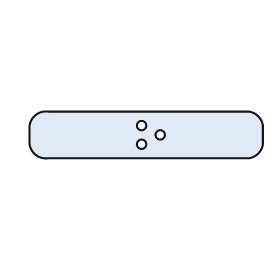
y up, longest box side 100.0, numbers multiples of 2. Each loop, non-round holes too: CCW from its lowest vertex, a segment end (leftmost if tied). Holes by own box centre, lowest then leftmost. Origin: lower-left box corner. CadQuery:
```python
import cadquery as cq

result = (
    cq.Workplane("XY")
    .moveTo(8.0, 0.0)
    .lineTo(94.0, 0.0)
    .threePointArc((98.0, 2.0), (100.0, 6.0))
    .lineTo(100.0, 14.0)
    .threePointArc((98.0, 18.0), (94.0, 20.0))
    .lineTo(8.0, 20.0)
    .threePointArc((2.0, 18.0), (0.0, 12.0))
    .lineTo(0.0, 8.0)
    .threePointArc((2.0, 2.0), (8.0, 0.0))
    .close()
    .moveTo(48.0, 6.0)
    .circle(2.0)
    .moveTo(56.0, 10.0)
    .circle(2.0)
    .moveTo(48.0, 14.0)
    .circle(2.0)
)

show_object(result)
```